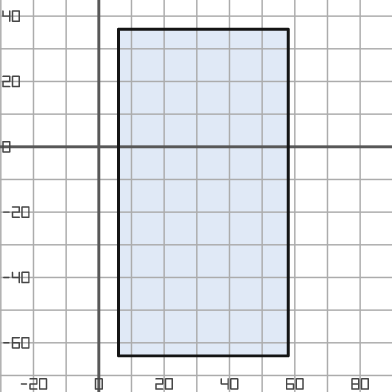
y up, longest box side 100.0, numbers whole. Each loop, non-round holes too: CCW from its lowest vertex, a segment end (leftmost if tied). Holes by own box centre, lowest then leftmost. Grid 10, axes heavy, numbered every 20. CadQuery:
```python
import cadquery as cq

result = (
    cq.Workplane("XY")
    .moveTo(6.0, -64.0)
    .lineTo(58.0, -64.0)
    .lineTo(58.0, 36.0)
    .lineTo(6.0, 36.0)
    .close()
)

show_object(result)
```